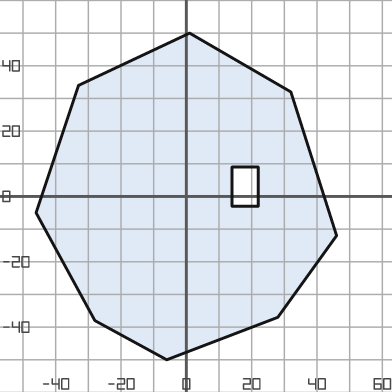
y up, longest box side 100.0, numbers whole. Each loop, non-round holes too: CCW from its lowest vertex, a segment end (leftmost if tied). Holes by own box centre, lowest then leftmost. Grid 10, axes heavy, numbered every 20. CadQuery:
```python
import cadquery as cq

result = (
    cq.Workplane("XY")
    .moveTo(-6.0, -50.0)
    .lineTo(28.0, -37.0)
    .lineTo(46.0, -12.0)
    .lineTo(32.0, 32.0)
    .lineTo(1.0, 50.0)
    .lineTo(-33.0, 34.0)
    .lineTo(-46.0, -5.0)
    .lineTo(-28.0, -38.0)
    .close()
    .moveTo(14.0, -3.0)
    .lineTo(22.0, -3.0)
    .lineTo(22.0, 9.0)
    .lineTo(14.0, 9.0)
    .close()
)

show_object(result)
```